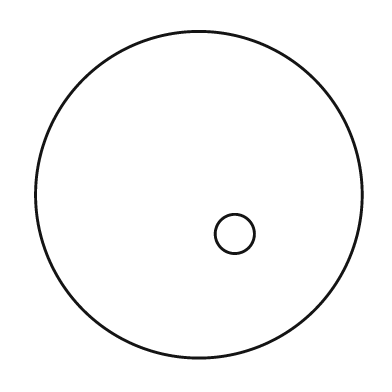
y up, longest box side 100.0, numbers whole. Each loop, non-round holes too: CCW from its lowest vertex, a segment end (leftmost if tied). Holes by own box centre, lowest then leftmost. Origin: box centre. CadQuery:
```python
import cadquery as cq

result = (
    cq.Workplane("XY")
    .moveTo(0.0, 0.0)
    .circle(50.0)
    .moveTo(11.0, -12.0)
    .circle(6.0)
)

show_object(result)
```